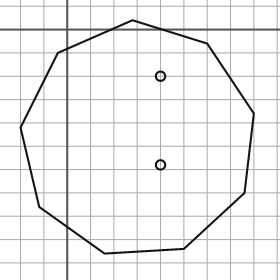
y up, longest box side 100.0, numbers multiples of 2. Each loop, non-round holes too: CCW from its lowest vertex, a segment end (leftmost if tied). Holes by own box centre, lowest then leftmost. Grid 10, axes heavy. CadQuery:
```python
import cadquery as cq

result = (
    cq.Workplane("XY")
    .moveTo(16.0, -96.0)
    .lineTo(50.0, -94.0)
    .lineTo(76.0, -70.0)
    .lineTo(80.0, -36.0)
    .lineTo(60.0, -6.0)
    .lineTo(28.0, 4.0)
    .lineTo(-4.0, -10.0)
    .lineTo(-20.0, -42.0)
    .lineTo(-12.0, -76.0)
    .close()
    .moveTo(40.0, -58.0)
    .circle(2.0)
    .moveTo(40.0, -20.0)
    .circle(2.0)
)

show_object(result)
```